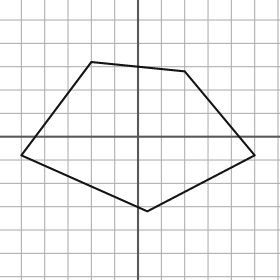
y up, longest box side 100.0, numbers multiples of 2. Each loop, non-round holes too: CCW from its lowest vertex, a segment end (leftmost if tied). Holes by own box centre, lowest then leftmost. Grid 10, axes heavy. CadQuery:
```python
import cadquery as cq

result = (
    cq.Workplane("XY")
    .moveTo(4.0, -32.0)
    .lineTo(50.0, -8.0)
    .lineTo(20.0, 28.0)
    .lineTo(-20.0, 32.0)
    .lineTo(-50.0, -8.0)
    .close()
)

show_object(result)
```